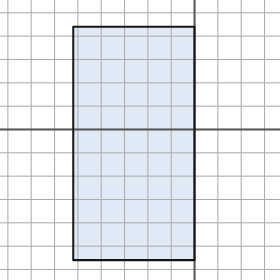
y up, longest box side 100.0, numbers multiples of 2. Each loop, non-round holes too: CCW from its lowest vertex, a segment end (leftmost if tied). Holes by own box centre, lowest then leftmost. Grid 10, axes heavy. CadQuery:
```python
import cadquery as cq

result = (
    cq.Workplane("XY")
    .moveTo(-52.0, -56.0)
    .lineTo(0.0, -56.0)
    .lineTo(0.0, 44.0)
    .lineTo(-52.0, 44.0)
    .close()
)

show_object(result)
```